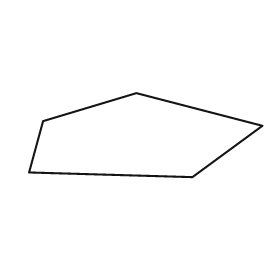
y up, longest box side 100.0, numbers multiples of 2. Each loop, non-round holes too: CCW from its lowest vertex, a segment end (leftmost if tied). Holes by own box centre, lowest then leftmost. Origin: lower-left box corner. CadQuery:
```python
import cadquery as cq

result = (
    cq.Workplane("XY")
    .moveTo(70.0, 0.0)
    .lineTo(100.0, 22.0)
    .lineTo(46.0, 36.0)
    .lineTo(6.0, 24.0)
    .lineTo(0.0, 2.0)
    .close()
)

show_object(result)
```